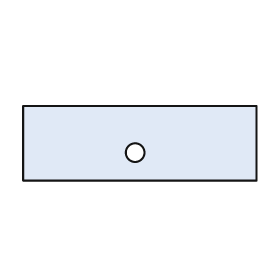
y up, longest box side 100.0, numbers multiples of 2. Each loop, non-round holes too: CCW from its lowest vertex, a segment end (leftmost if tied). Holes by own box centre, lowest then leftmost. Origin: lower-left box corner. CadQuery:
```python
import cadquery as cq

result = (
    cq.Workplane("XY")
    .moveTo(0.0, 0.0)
    .lineTo(100.0, 0.0)
    .lineTo(100.0, 32.0)
    .lineTo(0.0, 32.0)
    .close()
    .moveTo(48.0, 12.0)
    .circle(4.0)
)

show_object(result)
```